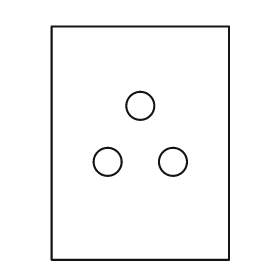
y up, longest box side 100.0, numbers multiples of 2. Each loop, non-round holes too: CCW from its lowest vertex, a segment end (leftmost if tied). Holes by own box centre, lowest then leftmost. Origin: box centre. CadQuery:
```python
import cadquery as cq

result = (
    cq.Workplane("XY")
    .moveTo(-38.0, -50.0)
    .lineTo(38.0, -50.0)
    .lineTo(38.0, 50.0)
    .lineTo(-38.0, 50.0)
    .close()
    .moveTo(-14.0, -8.0)
    .circle(6.0)
    .moveTo(14.0, -8.0)
    .circle(6.0)
    .moveTo(0.0, 16.0)
    .circle(6.0)
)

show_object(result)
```